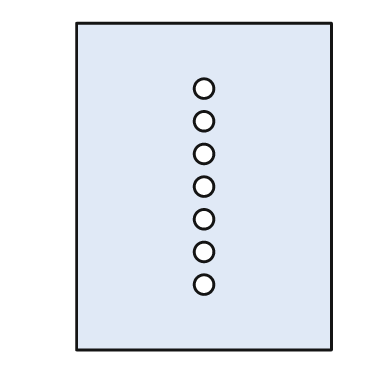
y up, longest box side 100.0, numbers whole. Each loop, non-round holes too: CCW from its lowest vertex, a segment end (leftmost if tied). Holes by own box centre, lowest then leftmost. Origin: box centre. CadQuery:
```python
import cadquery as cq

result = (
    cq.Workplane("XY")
    .moveTo(-39.0, -50.0)
    .lineTo(39.0, -50.0)
    .lineTo(39.0, 50.0)
    .lineTo(-39.0, 50.0)
    .close()
    .moveTo(0.0, -30.0)
    .circle(3.0)
    .moveTo(0.0, -20.0)
    .circle(3.0)
    .moveTo(0.0, -10.0)
    .circle(3.0)
    .moveTo(0.0, 0.0)
    .circle(3.0)
    .moveTo(0.0, 10.0)
    .circle(3.0)
    .moveTo(0.0, 20.0)
    .circle(3.0)
    .moveTo(0.0, 30.0)
    .circle(3.0)
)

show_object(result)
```